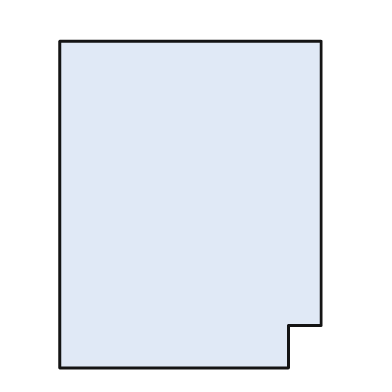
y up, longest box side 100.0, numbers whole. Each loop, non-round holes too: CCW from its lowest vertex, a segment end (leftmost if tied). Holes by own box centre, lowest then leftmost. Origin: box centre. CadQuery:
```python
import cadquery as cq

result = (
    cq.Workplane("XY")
    .moveTo(-40.0, -50.0)
    .lineTo(30.0, -50.0)
    .lineTo(30.0, -37.0)
    .lineTo(40.0, -37.0)
    .lineTo(40.0, 50.0)
    .lineTo(-40.0, 50.0)
    .close()
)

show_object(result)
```